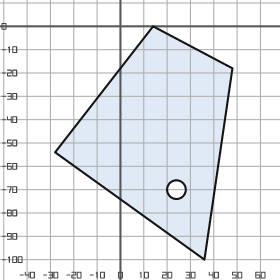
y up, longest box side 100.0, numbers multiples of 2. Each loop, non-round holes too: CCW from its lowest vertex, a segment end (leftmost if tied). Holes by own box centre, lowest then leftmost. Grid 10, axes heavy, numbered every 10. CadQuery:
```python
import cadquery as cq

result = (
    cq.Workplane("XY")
    .moveTo(36.0, -100.0)
    .lineTo(48.0, -18.0)
    .lineTo(14.0, 0.0)
    .lineTo(-28.0, -54.0)
    .close()
    .moveTo(24.0, -70.0)
    .circle(4.0)
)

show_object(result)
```